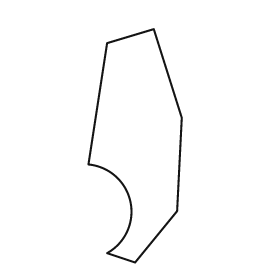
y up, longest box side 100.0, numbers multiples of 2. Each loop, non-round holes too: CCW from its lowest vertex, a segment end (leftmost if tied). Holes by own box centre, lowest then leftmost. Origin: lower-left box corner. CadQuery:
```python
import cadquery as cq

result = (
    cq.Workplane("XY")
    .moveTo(20.0, 0.0)
    .lineTo(38.0, 22.0)
    .lineTo(40.0, 62.0)
    .lineTo(28.0, 100.0)
    .lineTo(8.0, 94.0)
    .lineTo(0.0, 42.0)
    .threePointArc((18.0, 26.0), (8.0, 4.0))
    .close()
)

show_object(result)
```